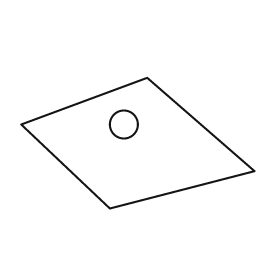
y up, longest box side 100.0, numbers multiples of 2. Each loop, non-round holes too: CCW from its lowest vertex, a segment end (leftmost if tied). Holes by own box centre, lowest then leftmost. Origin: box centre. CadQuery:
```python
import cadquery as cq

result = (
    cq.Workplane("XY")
    .moveTo(-12.0, -28.0)
    .lineTo(50.0, -12.0)
    .lineTo(4.0, 28.0)
    .lineTo(-50.0, 8.0)
    .close()
    .moveTo(-6.0, 8.0)
    .circle(6.0)
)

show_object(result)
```